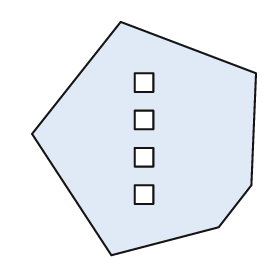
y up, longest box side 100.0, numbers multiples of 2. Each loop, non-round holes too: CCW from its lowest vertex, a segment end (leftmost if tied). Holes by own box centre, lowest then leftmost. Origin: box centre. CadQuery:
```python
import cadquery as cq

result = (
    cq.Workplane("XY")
    .moveTo(-14.0, -50.0)
    .lineTo(32.0, -38.0)
    .lineTo(46.0, -20.0)
    .lineTo(48.0, 28.0)
    .lineTo(-10.0, 50.0)
    .lineTo(-48.0, 2.0)
    .close()
    .moveTo(-4.0, -28.0)
    .lineTo(4.0, -28.0)
    .lineTo(4.0, -20.0)
    .lineTo(-4.0, -20.0)
    .close()
    .moveTo(-4.0, -12.0)
    .lineTo(4.0, -12.0)
    .lineTo(4.0, -4.0)
    .lineTo(-4.0, -4.0)
    .close()
    .moveTo(-4.0, 4.0)
    .lineTo(4.0, 4.0)
    .lineTo(4.0, 12.0)
    .lineTo(-4.0, 12.0)
    .close()
    .moveTo(-4.0, 20.0)
    .lineTo(4.0, 20.0)
    .lineTo(4.0, 28.0)
    .lineTo(-4.0, 28.0)
    .close()
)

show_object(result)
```